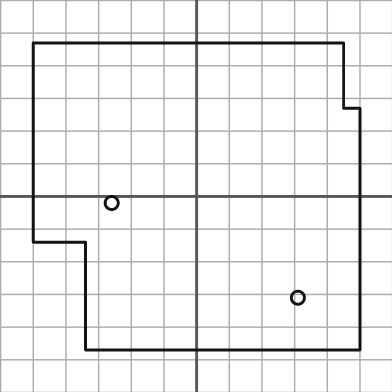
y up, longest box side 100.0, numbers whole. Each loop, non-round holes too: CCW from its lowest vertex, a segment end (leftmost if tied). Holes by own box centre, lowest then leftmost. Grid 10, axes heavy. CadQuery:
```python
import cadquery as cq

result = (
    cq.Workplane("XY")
    .moveTo(-34.0, -47.0)
    .lineTo(50.0, -47.0)
    .lineTo(50.0, 27.0)
    .lineTo(45.0, 27.0)
    .lineTo(45.0, 47.0)
    .lineTo(-50.0, 47.0)
    .lineTo(-50.0, -14.0)
    .lineTo(-34.0, -14.0)
    .close()
    .moveTo(31.0, -31.0)
    .circle(2.0)
    .moveTo(-26.0, -2.0)
    .circle(2.0)
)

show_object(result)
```